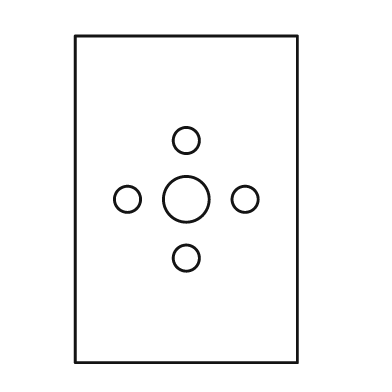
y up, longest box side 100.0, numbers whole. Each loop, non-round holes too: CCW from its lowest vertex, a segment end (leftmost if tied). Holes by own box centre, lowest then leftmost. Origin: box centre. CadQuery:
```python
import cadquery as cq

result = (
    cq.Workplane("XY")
    .moveTo(-34.0, -50.0)
    .lineTo(34.0, -50.0)
    .lineTo(34.0, 50.0)
    .lineTo(-34.0, 50.0)
    .close()
    .moveTo(0.0, -18.0)
    .circle(4.0)
    .moveTo(-18.0, 0.0)
    .circle(4.0)
    .moveTo(0.0, 0.0)
    .circle(7.0)
    .moveTo(18.0, 0.0)
    .circle(4.0)
    .moveTo(0.0, 18.0)
    .circle(4.0)
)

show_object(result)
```